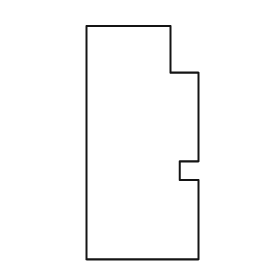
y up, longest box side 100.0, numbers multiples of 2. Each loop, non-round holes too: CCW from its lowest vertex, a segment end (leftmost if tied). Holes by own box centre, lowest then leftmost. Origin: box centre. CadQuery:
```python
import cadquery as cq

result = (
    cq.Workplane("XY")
    .moveTo(-24.0, -50.0)
    .lineTo(24.0, -50.0)
    .lineTo(24.0, -16.0)
    .lineTo(16.0, -16.0)
    .lineTo(16.0, -8.0)
    .lineTo(24.0, -8.0)
    .lineTo(24.0, 30.0)
    .lineTo(12.0, 30.0)
    .lineTo(12.0, 50.0)
    .lineTo(-24.0, 50.0)
    .close()
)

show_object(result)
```